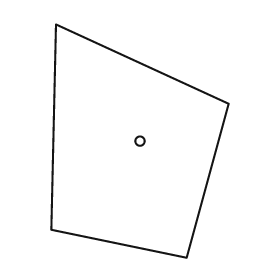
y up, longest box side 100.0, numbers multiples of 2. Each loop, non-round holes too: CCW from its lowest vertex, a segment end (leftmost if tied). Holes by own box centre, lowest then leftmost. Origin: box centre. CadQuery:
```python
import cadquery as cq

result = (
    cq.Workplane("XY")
    .moveTo(20.0, -50.0)
    .lineTo(38.0, 16.0)
    .lineTo(-36.0, 50.0)
    .lineTo(-38.0, -38.0)
    .close()
    .moveTo(0.0, 0.0)
    .circle(2.0)
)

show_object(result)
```